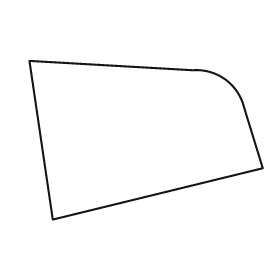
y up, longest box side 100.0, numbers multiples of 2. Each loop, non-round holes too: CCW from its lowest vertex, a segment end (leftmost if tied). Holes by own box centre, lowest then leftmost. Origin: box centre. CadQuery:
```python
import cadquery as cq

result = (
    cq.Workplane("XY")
    .moveTo(-40.0, -34.0)
    .lineTo(50.0, -12.0)
    .lineTo(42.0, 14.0)
    .threePointArc((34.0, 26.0), (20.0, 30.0))
    .lineTo(-50.0, 34.0)
    .close()
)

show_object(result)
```